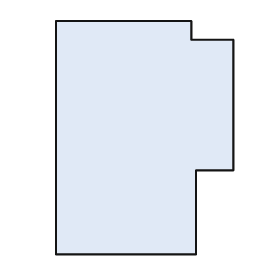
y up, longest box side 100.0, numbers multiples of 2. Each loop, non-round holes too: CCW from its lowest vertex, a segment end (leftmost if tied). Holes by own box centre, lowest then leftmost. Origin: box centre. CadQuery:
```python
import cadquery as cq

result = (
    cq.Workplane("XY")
    .moveTo(-38.0, -50.0)
    .lineTo(22.0, -50.0)
    .lineTo(22.0, -14.0)
    .lineTo(38.0, -14.0)
    .lineTo(38.0, 42.0)
    .lineTo(20.0, 42.0)
    .lineTo(20.0, 50.0)
    .lineTo(-38.0, 50.0)
    .close()
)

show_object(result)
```